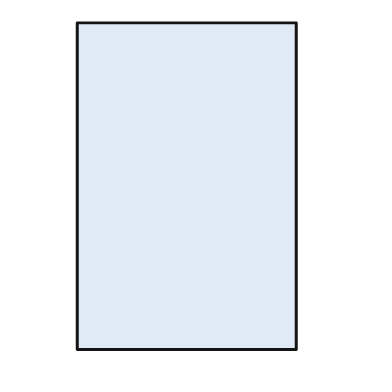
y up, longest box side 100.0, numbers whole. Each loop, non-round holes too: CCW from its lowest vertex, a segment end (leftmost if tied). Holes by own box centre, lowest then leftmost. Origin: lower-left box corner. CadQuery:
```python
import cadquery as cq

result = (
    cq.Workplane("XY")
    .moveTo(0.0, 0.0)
    .lineTo(67.0, 0.0)
    .lineTo(67.0, 100.0)
    .lineTo(0.0, 100.0)
    .close()
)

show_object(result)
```